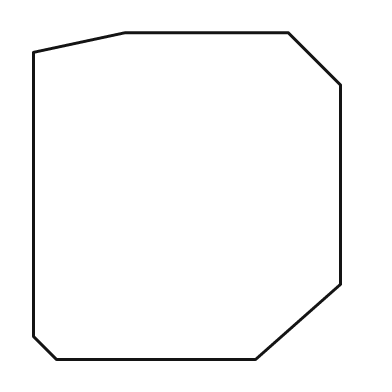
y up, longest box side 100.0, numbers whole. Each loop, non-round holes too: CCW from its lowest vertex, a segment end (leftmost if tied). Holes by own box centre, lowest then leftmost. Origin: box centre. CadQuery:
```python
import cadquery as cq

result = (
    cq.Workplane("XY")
    .moveTo(-40.0, -50.0)
    .lineTo(21.0, -50.0)
    .lineTo(47.0, -27.0)
    .lineTo(47.0, 34.0)
    .lineTo(31.0, 50.0)
    .lineTo(-19.0, 50.0)
    .lineTo(-47.0, 44.0)
    .lineTo(-47.0, -43.0)
    .close()
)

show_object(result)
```